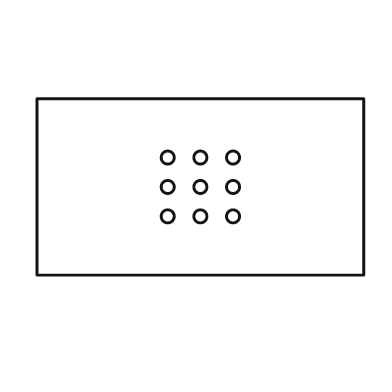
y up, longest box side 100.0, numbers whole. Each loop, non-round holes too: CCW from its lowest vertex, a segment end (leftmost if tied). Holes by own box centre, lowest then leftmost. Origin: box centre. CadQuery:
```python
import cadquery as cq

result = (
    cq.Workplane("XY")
    .moveTo(-50.0, -27.0)
    .lineTo(50.0, -27.0)
    .lineTo(50.0, 27.0)
    .lineTo(-50.0, 27.0)
    .close()
    .moveTo(-10.0, -9.0)
    .circle(2.0)
    .moveTo(0.0, -9.0)
    .circle(2.0)
    .moveTo(10.0, -9.0)
    .circle(2.0)
    .moveTo(-10.0, 0.0)
    .circle(2.0)
    .moveTo(0.0, 0.0)
    .circle(2.0)
    .moveTo(10.0, 0.0)
    .circle(2.0)
    .moveTo(-10.0, 9.0)
    .circle(2.0)
    .moveTo(0.0, 9.0)
    .circle(2.0)
    .moveTo(10.0, 9.0)
    .circle(2.0)
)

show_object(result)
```